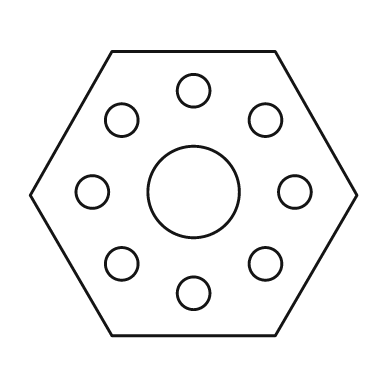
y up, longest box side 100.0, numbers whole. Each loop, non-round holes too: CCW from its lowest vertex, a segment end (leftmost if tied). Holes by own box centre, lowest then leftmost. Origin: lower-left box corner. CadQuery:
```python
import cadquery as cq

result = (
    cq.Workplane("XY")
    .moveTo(25.0, 0.0)
    .lineTo(75.0, 0.0)
    .lineTo(100.0, 43.0)
    .lineTo(75.0, 87.0)
    .lineTo(25.0, 87.0)
    .lineTo(0.0, 43.0)
    .close()
    .moveTo(50.0, 13.0)
    .circle(5.0)
    .moveTo(28.0, 22.0)
    .circle(5.0)
    .moveTo(72.0, 22.0)
    .circle(5.0)
    .moveTo(19.0, 44.0)
    .circle(5.0)
    .moveTo(50.0, 44.0)
    .circle(14.0)
    .moveTo(81.0, 44.0)
    .circle(5.0)
    .moveTo(28.0, 66.0)
    .circle(5.0)
    .moveTo(72.0, 66.0)
    .circle(5.0)
    .moveTo(50.0, 75.0)
    .circle(5.0)
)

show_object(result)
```